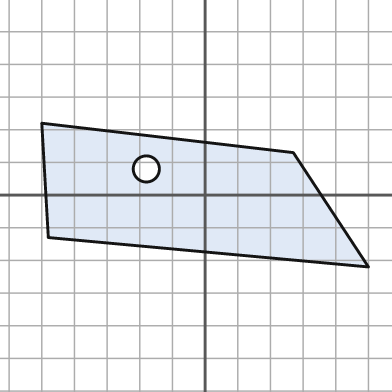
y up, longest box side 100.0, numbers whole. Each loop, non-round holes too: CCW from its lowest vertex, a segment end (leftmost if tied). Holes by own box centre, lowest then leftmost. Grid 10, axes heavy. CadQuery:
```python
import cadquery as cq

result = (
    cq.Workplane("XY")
    .moveTo(50.0, -22.0)
    .lineTo(27.0, 13.0)
    .lineTo(-50.0, 22.0)
    .lineTo(-48.0, -13.0)
    .close()
    .moveTo(-18.0, 8.0)
    .circle(4.0)
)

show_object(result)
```